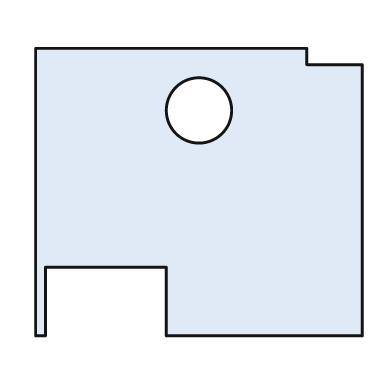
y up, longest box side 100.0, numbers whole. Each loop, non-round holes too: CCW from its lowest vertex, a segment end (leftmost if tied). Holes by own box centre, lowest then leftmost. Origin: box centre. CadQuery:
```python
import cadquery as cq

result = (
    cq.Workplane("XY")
    .moveTo(-50.0, -44.0)
    .lineTo(-47.0, -44.0)
    .lineTo(-47.0, -23.0)
    .lineTo(-10.0, -23.0)
    .lineTo(-10.0, -44.0)
    .lineTo(50.0, -44.0)
    .lineTo(50.0, 39.0)
    .lineTo(33.0, 39.0)
    .lineTo(33.0, 44.0)
    .lineTo(-50.0, 44.0)
    .close()
    .moveTo(0.0, 25.0)
    .circle(10.0)
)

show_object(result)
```